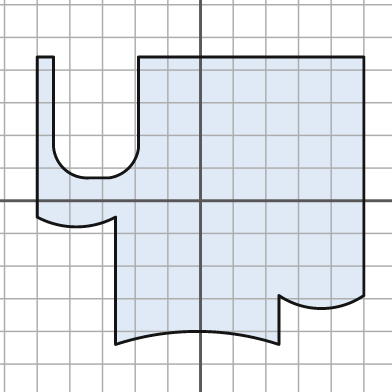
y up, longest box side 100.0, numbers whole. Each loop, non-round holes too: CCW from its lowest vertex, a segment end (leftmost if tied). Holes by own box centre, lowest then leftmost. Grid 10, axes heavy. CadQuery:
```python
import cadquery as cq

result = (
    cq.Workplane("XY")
    .moveTo(-26.0, -44.0)
    .threePointArc((-1.0, -40.0), (24.0, -44.0))
    .lineTo(24.0, -29.0)
    .threePointArc((37.0, -33.0), (50.0, -29.0))
    .lineTo(50.0, 44.0)
    .lineTo(-19.0, 44.0)
    .lineTo(-19.0, 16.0)
    .threePointArc((-22.0, 10.0), (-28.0, 7.0))
    .lineTo(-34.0, 7.0)
    .threePointArc((-42.0, 10.0), (-45.0, 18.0))
    .lineTo(-45.0, 44.0)
    .lineTo(-50.0, 44.0)
    .lineTo(-50.0, -5.0)
    .threePointArc((-38.0, -8.0), (-26.0, -5.0))
    .close()
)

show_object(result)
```